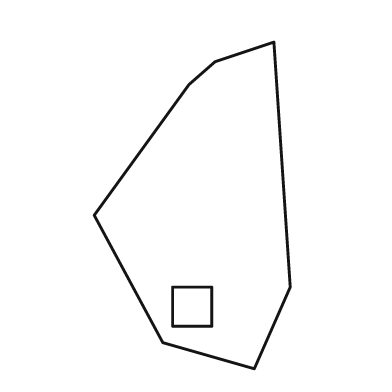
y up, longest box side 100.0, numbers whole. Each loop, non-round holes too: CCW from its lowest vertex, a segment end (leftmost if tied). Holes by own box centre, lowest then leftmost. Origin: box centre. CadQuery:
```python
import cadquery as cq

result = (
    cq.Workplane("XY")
    .moveTo(19.0, -50.0)
    .lineTo(30.0, -25.0)
    .lineTo(25.0, 50.0)
    .lineTo(7.0, 44.0)
    .lineTo(-1.0, 37.0)
    .lineTo(-30.0, -3.0)
    .lineTo(-9.0, -42.0)
    .close()
    .moveTo(-6.0, -37.0)
    .lineTo(6.0, -37.0)
    .lineTo(6.0, -25.0)
    .lineTo(-6.0, -25.0)
    .close()
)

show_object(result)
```